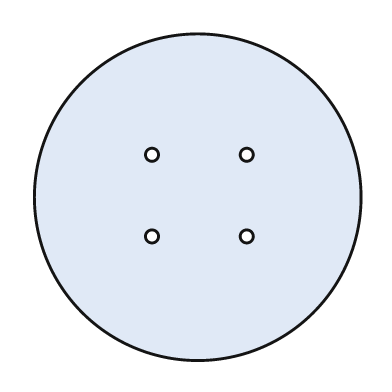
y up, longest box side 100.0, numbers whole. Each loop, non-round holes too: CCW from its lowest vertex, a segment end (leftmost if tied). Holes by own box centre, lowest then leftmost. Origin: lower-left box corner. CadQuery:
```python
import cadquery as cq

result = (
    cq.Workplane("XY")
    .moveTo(50.0, 50.0)
    .circle(50.0)
    .moveTo(36.0, 38.0)
    .circle(2.0)
    .moveTo(65.0, 38.0)
    .circle(2.0)
    .moveTo(36.0, 63.0)
    .circle(2.0)
    .moveTo(65.0, 63.0)
    .circle(2.0)
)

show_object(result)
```